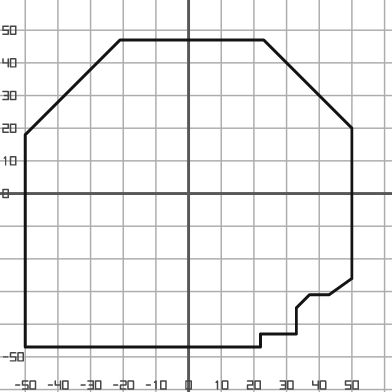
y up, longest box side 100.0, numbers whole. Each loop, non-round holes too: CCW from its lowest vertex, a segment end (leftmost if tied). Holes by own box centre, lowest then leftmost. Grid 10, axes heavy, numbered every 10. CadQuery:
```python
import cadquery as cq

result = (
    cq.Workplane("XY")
    .moveTo(-50.0, -47.0)
    .lineTo(22.0, -47.0)
    .lineTo(22.0, -43.0)
    .lineTo(33.0, -43.0)
    .lineTo(33.0, -35.0)
    .lineTo(37.0, -31.0)
    .lineTo(43.0, -31.0)
    .lineTo(50.0, -26.0)
    .lineTo(50.0, 20.0)
    .lineTo(23.0, 47.0)
    .lineTo(-21.0, 47.0)
    .lineTo(-50.0, 18.0)
    .close()
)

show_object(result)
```